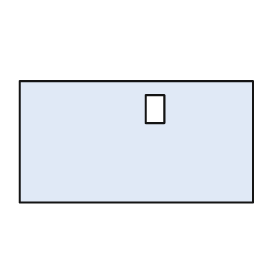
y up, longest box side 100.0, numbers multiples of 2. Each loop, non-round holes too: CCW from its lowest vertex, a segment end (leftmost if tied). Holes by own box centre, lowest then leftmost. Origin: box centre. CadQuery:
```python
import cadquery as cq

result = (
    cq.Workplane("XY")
    .moveTo(-50.0, -26.0)
    .lineTo(50.0, -26.0)
    .lineTo(50.0, 26.0)
    .lineTo(-50.0, 26.0)
    .close()
    .moveTo(4.0, 8.0)
    .lineTo(12.0, 8.0)
    .lineTo(12.0, 20.0)
    .lineTo(4.0, 20.0)
    .close()
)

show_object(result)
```